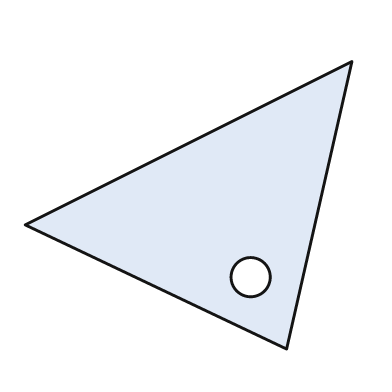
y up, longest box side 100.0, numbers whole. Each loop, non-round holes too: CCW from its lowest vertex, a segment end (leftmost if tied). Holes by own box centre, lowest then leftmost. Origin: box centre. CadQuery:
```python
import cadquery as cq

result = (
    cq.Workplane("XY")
    .moveTo(30.0, -44.0)
    .lineTo(50.0, 44.0)
    .lineTo(-50.0, -6.0)
    .close()
    .moveTo(19.0, -22.0)
    .circle(6.0)
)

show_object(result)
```